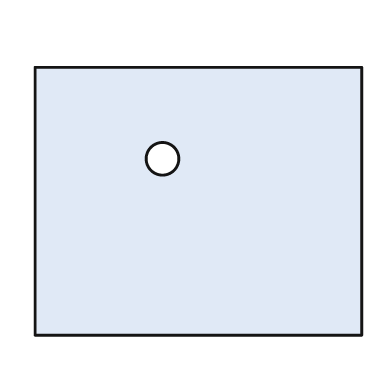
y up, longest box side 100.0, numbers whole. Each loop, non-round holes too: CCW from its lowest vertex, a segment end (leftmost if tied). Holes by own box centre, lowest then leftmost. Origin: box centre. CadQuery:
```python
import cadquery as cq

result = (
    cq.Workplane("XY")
    .moveTo(-50.0, -41.0)
    .lineTo(50.0, -41.0)
    .lineTo(50.0, 41.0)
    .lineTo(-50.0, 41.0)
    .close()
    .moveTo(-11.0, 13.0)
    .circle(5.0)
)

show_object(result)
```